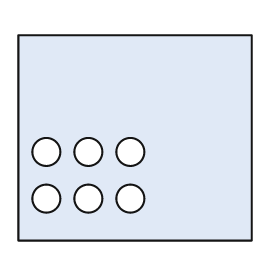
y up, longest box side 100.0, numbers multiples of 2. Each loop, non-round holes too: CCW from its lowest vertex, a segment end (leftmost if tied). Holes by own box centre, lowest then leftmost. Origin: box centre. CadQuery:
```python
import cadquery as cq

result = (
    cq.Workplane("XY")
    .moveTo(-50.0, -44.0)
    .lineTo(50.0, -44.0)
    .lineTo(50.0, 44.0)
    .lineTo(-50.0, 44.0)
    .close()
    .moveTo(-38.0, -26.0)
    .circle(6.0)
    .moveTo(-20.0, -26.0)
    .circle(6.0)
    .moveTo(-2.0, -26.0)
    .circle(6.0)
    .moveTo(-38.0, -6.0)
    .circle(6.0)
    .moveTo(-20.0, -6.0)
    .circle(6.0)
    .moveTo(-2.0, -6.0)
    .circle(6.0)
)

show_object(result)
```